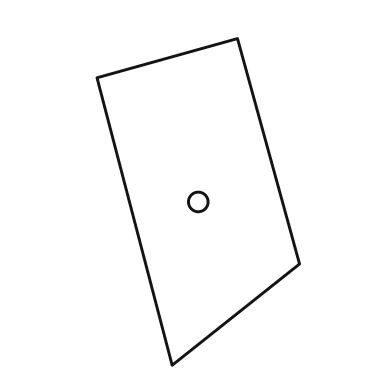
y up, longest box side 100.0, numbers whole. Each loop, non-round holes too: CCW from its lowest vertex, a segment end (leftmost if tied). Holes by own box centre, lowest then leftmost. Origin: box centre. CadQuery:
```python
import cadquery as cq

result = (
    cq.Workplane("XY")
    .moveTo(-8.0, -50.0)
    .lineTo(31.0, -19.0)
    .lineTo(12.0, 50.0)
    .lineTo(-31.0, 38.0)
    .close()
    .moveTo(0.0, 0.0)
    .circle(3.0)
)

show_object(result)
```